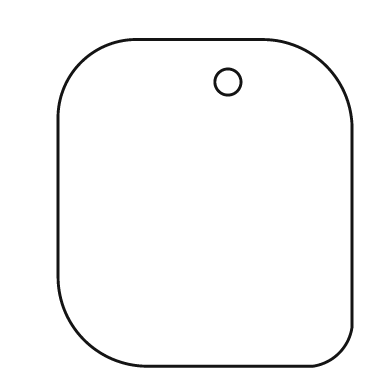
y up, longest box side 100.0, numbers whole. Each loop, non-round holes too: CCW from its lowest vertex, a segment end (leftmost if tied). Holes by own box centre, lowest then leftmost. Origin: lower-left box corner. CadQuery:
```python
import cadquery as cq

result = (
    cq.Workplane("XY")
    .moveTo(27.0, 0.0)
    .lineTo(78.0, 0.0)
    .threePointArc((86.0, 4.0), (90.0, 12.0))
    .lineTo(90.0, 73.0)
    .threePointArc((82.0, 92.0), (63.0, 100.0))
    .lineTo(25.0, 100.0)
    .threePointArc((7.0, 93.0), (0.0, 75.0))
    .lineTo(0.0, 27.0)
    .threePointArc((8.0, 8.0), (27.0, 0.0))
    .close()
    .moveTo(52.0, 87.0)
    .circle(4.0)
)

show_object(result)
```